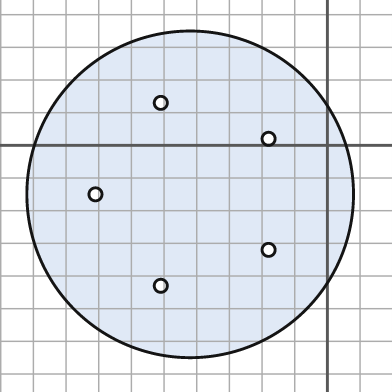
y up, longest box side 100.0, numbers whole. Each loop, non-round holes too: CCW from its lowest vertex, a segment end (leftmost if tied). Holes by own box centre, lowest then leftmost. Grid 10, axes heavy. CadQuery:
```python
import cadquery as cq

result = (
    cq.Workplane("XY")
    .moveTo(-42.0, -15.0)
    .circle(50.0)
    .moveTo(-51.0, -43.0)
    .circle(2.0)
    .moveTo(-18.0, -32.0)
    .circle(2.0)
    .moveTo(-71.0, -15.0)
    .circle(2.0)
    .moveTo(-18.0, 2.0)
    .circle(2.0)
    .moveTo(-51.0, 13.0)
    .circle(2.0)
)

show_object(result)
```